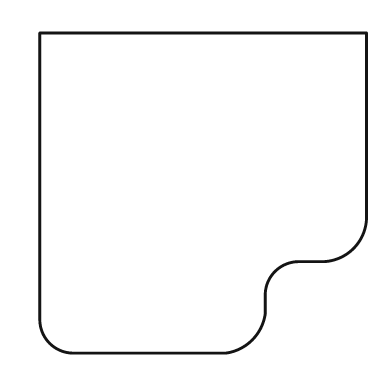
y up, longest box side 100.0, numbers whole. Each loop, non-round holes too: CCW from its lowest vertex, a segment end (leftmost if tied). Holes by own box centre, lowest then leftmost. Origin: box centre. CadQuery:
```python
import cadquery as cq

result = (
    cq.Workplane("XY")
    .moveTo(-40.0, -49.0)
    .lineTo(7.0, -49.0)
    .threePointArc((15.0, -45.0), (19.0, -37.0))
    .lineTo(19.0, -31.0)
    .threePointArc((22.0, -24.0), (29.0, -21.0))
    .lineTo(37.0, -21.0)
    .threePointArc((46.0, -17.0), (50.0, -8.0))
    .lineTo(50.0, 49.0)
    .lineTo(-50.0, 49.0)
    .lineTo(-50.0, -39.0)
    .threePointArc((-47.0, -46.0), (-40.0, -49.0))
    .close()
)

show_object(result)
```